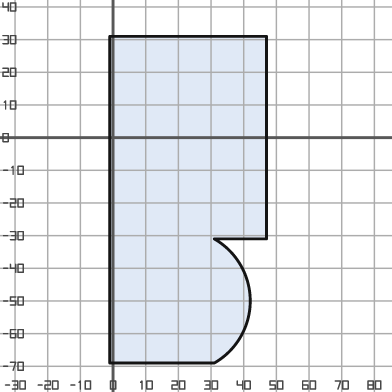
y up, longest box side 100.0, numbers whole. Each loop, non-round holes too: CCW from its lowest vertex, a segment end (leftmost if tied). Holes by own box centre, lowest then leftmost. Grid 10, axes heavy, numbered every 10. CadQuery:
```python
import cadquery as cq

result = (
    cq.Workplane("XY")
    .moveTo(-1.0, -69.0)
    .lineTo(31.0, -69.0)
    .threePointArc((42.0, -50.0), (31.0, -31.0))
    .lineTo(47.0, -31.0)
    .lineTo(47.0, 31.0)
    .lineTo(-1.0, 31.0)
    .close()
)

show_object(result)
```